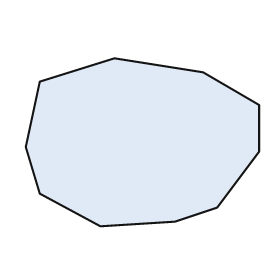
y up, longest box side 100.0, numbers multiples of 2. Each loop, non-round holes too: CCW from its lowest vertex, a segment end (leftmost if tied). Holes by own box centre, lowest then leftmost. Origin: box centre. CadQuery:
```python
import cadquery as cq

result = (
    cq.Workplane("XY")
    .moveTo(-18.0, -36.0)
    .lineTo(14.0, -34.0)
    .lineTo(32.0, -28.0)
    .lineTo(50.0, -4.0)
    .lineTo(50.0, 16.0)
    .lineTo(26.0, 30.0)
    .lineTo(-12.0, 36.0)
    .lineTo(-44.0, 26.0)
    .lineTo(-50.0, -2.0)
    .lineTo(-44.0, -22.0)
    .close()
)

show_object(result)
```